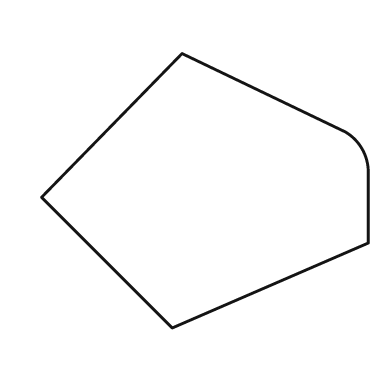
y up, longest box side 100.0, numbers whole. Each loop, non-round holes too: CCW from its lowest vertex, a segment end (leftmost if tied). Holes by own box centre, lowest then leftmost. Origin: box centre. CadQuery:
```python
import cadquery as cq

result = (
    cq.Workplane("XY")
    .moveTo(-10.0, -42.0)
    .lineTo(50.0, -16.0)
    .lineTo(50.0, 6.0)
    .threePointArc((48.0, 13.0), (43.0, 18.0))
    .lineTo(-7.0, 42.0)
    .lineTo(-50.0, -2.0)
    .close()
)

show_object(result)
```